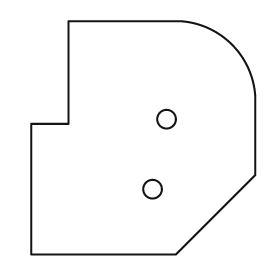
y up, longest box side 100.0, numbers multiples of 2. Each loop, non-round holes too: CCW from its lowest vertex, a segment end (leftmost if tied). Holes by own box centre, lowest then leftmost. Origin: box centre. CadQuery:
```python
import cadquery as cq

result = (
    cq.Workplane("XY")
    .moveTo(-48.0, -50.0)
    .lineTo(14.0, -50.0)
    .lineTo(48.0, -16.0)
    .lineTo(48.0, 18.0)
    .threePointArc((38.0, 40.0), (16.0, 50.0))
    .lineTo(-32.0, 50.0)
    .lineTo(-32.0, 6.0)
    .lineTo(-48.0, 6.0)
    .close()
    .moveTo(4.0, -22.0)
    .circle(4.0)
    .moveTo(10.0, 8.0)
    .circle(4.0)
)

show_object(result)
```